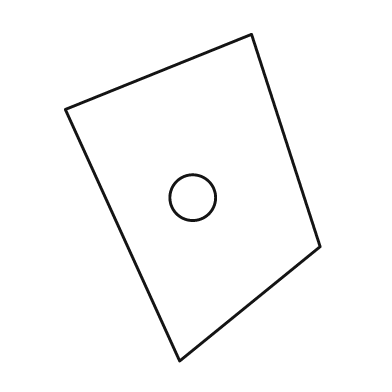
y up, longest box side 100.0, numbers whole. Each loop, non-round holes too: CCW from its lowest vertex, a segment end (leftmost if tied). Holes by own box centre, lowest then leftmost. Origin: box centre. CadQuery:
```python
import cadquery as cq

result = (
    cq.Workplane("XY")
    .moveTo(-4.0, -50.0)
    .lineTo(39.0, -15.0)
    .lineTo(18.0, 50.0)
    .lineTo(-39.0, 27.0)
    .close()
    .moveTo(0.0, 0.0)
    .circle(7.0)
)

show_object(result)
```